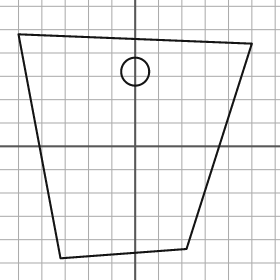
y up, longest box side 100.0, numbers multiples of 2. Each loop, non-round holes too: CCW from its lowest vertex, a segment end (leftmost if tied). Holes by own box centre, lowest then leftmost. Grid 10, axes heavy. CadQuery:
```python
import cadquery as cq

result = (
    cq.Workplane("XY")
    .moveTo(-32.0, -48.0)
    .lineTo(22.0, -44.0)
    .lineTo(50.0, 44.0)
    .lineTo(-50.0, 48.0)
    .close()
    .moveTo(0.0, 32.0)
    .circle(6.0)
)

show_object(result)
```